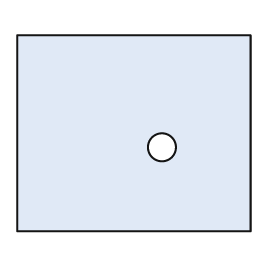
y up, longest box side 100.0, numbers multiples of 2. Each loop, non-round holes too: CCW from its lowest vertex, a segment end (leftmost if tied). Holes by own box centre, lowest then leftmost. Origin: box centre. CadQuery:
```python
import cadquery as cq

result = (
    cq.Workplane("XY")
    .moveTo(-50.0, -42.0)
    .lineTo(50.0, -42.0)
    .lineTo(50.0, 42.0)
    .lineTo(-50.0, 42.0)
    .close()
    .moveTo(12.0, -6.0)
    .circle(6.0)
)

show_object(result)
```